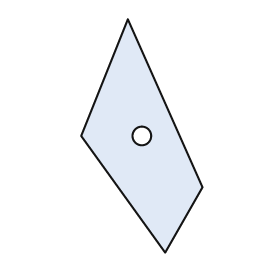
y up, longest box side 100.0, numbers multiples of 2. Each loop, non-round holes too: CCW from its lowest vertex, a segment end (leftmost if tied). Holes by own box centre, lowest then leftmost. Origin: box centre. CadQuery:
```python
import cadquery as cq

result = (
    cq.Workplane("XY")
    .moveTo(10.0, -50.0)
    .lineTo(26.0, -22.0)
    .lineTo(-6.0, 50.0)
    .lineTo(-26.0, 0.0)
    .close()
    .moveTo(0.0, 0.0)
    .circle(4.0)
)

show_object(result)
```